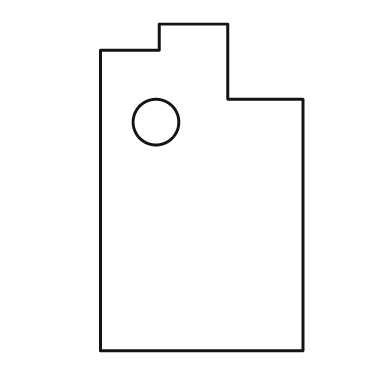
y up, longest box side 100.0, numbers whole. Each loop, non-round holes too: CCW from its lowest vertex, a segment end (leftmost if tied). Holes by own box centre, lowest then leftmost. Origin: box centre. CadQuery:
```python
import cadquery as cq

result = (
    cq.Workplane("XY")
    .moveTo(-31.0, -50.0)
    .lineTo(31.0, -50.0)
    .lineTo(31.0, 27.0)
    .lineTo(8.0, 27.0)
    .lineTo(8.0, 50.0)
    .lineTo(-13.0, 50.0)
    .lineTo(-13.0, 42.0)
    .lineTo(-31.0, 42.0)
    .close()
    .moveTo(-14.0, 20.0)
    .circle(7.0)
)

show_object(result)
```